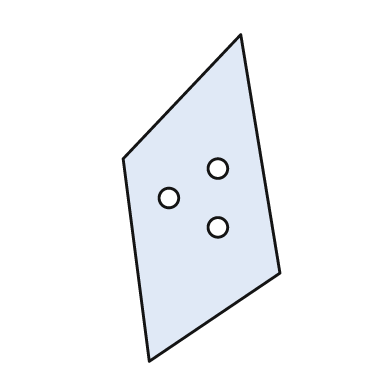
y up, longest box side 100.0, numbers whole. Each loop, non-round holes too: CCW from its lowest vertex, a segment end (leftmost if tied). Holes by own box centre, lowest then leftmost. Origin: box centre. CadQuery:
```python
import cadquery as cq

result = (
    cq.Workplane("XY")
    .moveTo(-16.0, -50.0)
    .lineTo(24.0, -23.0)
    .lineTo(12.0, 50.0)
    .lineTo(-24.0, 12.0)
    .close()
    .moveTo(5.0, -9.0)
    .circle(3.0)
    .moveTo(-10.0, 0.0)
    .circle(3.0)
    .moveTo(5.0, 9.0)
    .circle(3.0)
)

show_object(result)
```